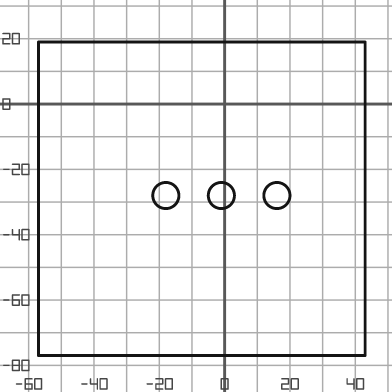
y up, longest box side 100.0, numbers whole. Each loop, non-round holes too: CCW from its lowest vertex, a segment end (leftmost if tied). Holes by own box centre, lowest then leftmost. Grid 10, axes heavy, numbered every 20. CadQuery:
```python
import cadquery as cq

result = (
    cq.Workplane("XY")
    .moveTo(-57.0, -77.0)
    .lineTo(43.0, -77.0)
    .lineTo(43.0, 19.0)
    .lineTo(-57.0, 19.0)
    .close()
    .moveTo(-18.0, -28.0)
    .circle(4.0)
    .moveTo(-1.0, -28.0)
    .circle(4.0)
    .moveTo(16.0, -28.0)
    .circle(4.0)
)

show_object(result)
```